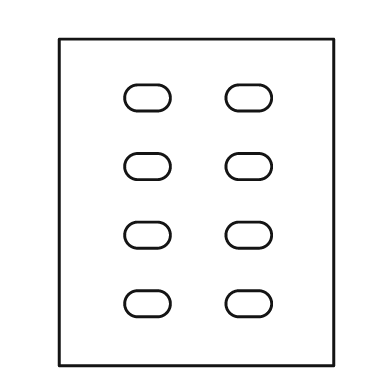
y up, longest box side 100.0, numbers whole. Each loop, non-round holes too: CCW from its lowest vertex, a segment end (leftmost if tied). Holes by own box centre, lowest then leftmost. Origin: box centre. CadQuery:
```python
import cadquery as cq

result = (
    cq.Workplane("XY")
    .moveTo(-42.0, -50.0)
    .lineTo(42.0, -50.0)
    .lineTo(42.0, 50.0)
    .lineTo(-42.0, 50.0)
    .close()
    .moveTo(-18.0, -35.0)
    .lineTo(-12.0, -35.0)
    .threePointArc((-8.0, -31.0), (-12.0, -27.0))
    .lineTo(-18.0, -27.0)
    .threePointArc((-22.0, -31.0), (-18.0, -35.0))
    .close()
    .moveTo(13.0, -35.0)
    .lineTo(19.0, -35.0)
    .threePointArc((23.0, -31.0), (19.0, -27.0))
    .lineTo(13.0, -27.0)
    .threePointArc((9.0, -31.0), (13.0, -35.0))
    .close()
    .moveTo(-18.0, -14.0)
    .lineTo(-12.0, -14.0)
    .threePointArc((-8.0, -10.0), (-12.0, -6.0))
    .lineTo(-18.0, -6.0)
    .threePointArc((-22.0, -10.0), (-18.0, -14.0))
    .close()
    .moveTo(13.0, -14.0)
    .lineTo(19.0, -14.0)
    .threePointArc((23.0, -10.0), (19.0, -6.0))
    .lineTo(13.0, -6.0)
    .threePointArc((9.0, -10.0), (13.0, -14.0))
    .close()
    .moveTo(-18.0, 7.0)
    .lineTo(-12.0, 7.0)
    .threePointArc((-8.0, 11.0), (-12.0, 15.0))
    .lineTo(-18.0, 15.0)
    .threePointArc((-22.0, 11.0), (-18.0, 7.0))
    .close()
    .moveTo(13.0, 7.0)
    .lineTo(19.0, 7.0)
    .threePointArc((23.0, 11.0), (19.0, 15.0))
    .lineTo(13.0, 15.0)
    .threePointArc((9.0, 11.0), (13.0, 7.0))
    .close()
    .moveTo(-18.0, 28.0)
    .lineTo(-12.0, 28.0)
    .threePointArc((-8.0, 32.0), (-12.0, 36.0))
    .lineTo(-18.0, 36.0)
    .threePointArc((-22.0, 32.0), (-18.0, 28.0))
    .close()
    .moveTo(13.0, 28.0)
    .lineTo(19.0, 28.0)
    .threePointArc((23.0, 32.0), (19.0, 36.0))
    .lineTo(13.0, 36.0)
    .threePointArc((9.0, 32.0), (13.0, 28.0))
    .close()
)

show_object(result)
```